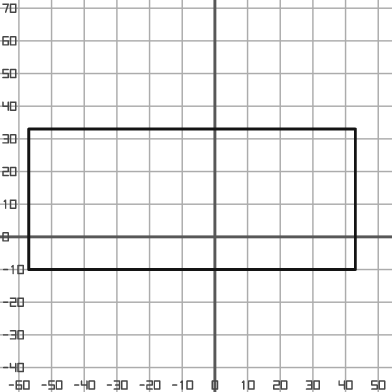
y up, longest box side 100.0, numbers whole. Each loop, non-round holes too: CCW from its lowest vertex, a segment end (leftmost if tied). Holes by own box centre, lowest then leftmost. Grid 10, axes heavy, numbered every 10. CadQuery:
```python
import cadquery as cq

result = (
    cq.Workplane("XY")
    .moveTo(-57.0, -10.0)
    .lineTo(43.0, -10.0)
    .lineTo(43.0, 33.0)
    .lineTo(-57.0, 33.0)
    .close()
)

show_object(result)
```